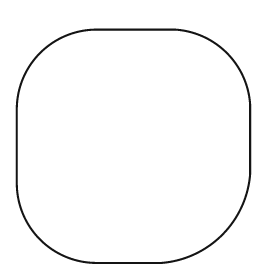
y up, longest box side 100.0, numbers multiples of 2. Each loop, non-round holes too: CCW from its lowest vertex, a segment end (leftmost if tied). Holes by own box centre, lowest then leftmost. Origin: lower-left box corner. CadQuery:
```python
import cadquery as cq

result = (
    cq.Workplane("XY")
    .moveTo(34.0, 0.0)
    .lineTo(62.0, 0.0)
    .threePointArc((88.0, 12.0), (100.0, 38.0))
    .lineTo(100.0, 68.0)
    .threePointArc((90.0, 90.0), (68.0, 100.0))
    .lineTo(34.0, 100.0)
    .threePointArc((10.0, 90.0), (0.0, 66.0))
    .lineTo(0.0, 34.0)
    .threePointArc((10.0, 10.0), (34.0, 0.0))
    .close()
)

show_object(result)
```